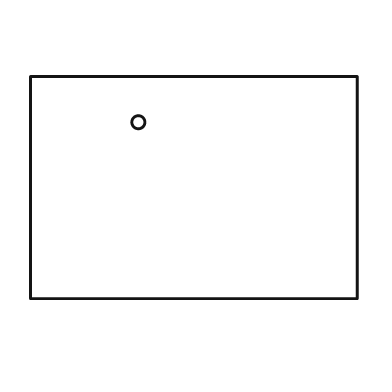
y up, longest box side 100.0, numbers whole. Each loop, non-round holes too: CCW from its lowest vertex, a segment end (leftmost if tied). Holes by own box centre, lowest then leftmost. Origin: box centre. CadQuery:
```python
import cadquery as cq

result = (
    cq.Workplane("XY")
    .moveTo(-50.0, -34.0)
    .lineTo(50.0, -34.0)
    .lineTo(50.0, 34.0)
    .lineTo(-50.0, 34.0)
    .close()
    .moveTo(-17.0, 20.0)
    .circle(2.0)
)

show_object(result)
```